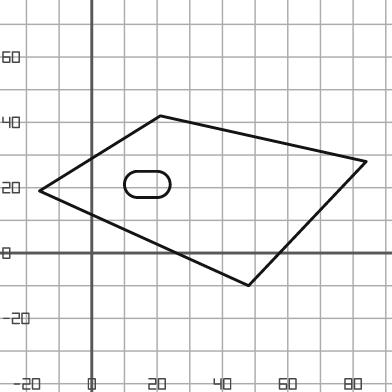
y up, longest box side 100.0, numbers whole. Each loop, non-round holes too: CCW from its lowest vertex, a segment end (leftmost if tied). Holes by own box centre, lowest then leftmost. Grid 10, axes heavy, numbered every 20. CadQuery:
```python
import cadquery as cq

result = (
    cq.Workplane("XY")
    .moveTo(48.0, -10.0)
    .lineTo(84.0, 28.0)
    .lineTo(21.0, 42.0)
    .lineTo(-16.0, 19.0)
    .close()
    .moveTo(14.0, 17.0)
    .lineTo(20.0, 17.0)
    .threePointArc((24.0, 21.0), (20.0, 25.0))
    .lineTo(14.0, 25.0)
    .threePointArc((10.0, 21.0), (14.0, 17.0))
    .close()
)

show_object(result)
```